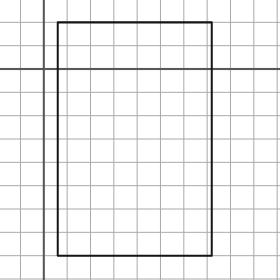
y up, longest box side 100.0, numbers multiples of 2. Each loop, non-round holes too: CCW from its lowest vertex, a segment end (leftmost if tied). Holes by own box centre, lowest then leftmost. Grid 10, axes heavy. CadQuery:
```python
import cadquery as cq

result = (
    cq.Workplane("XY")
    .moveTo(6.0, -80.0)
    .lineTo(72.0, -80.0)
    .lineTo(72.0, 20.0)
    .lineTo(6.0, 20.0)
    .close()
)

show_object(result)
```